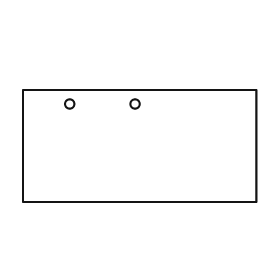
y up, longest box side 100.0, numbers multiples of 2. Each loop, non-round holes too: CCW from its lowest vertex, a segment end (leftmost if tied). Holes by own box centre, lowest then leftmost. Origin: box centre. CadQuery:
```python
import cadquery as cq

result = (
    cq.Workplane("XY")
    .moveTo(-50.0, -24.0)
    .lineTo(50.0, -24.0)
    .lineTo(50.0, 24.0)
    .lineTo(-50.0, 24.0)
    .close()
    .moveTo(-30.0, 18.0)
    .circle(2.0)
    .moveTo(-2.0, 18.0)
    .circle(2.0)
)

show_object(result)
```